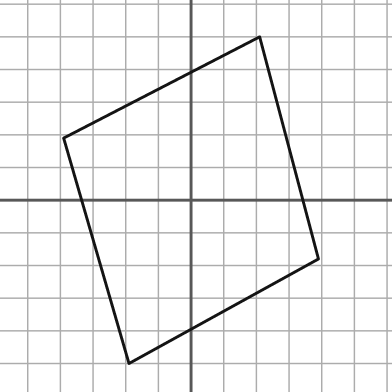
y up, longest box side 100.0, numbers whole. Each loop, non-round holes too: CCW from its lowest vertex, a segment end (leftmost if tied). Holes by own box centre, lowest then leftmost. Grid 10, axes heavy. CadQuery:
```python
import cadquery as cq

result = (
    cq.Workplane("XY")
    .moveTo(-19.0, -50.0)
    .lineTo(39.0, -18.0)
    .lineTo(21.0, 50.0)
    .lineTo(-39.0, 19.0)
    .close()
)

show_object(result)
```